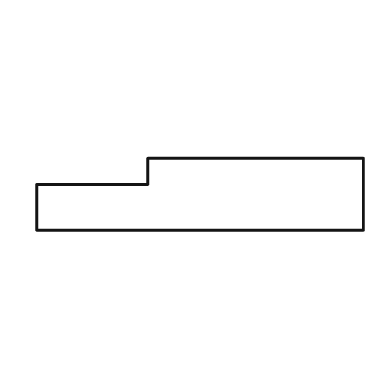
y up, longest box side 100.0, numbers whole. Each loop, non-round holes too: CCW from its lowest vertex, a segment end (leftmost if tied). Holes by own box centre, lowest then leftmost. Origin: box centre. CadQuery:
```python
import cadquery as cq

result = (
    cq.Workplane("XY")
    .moveTo(-50.0, -11.0)
    .lineTo(50.0, -11.0)
    .lineTo(50.0, 11.0)
    .lineTo(-16.0, 11.0)
    .lineTo(-16.0, 3.0)
    .lineTo(-50.0, 3.0)
    .close()
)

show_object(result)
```